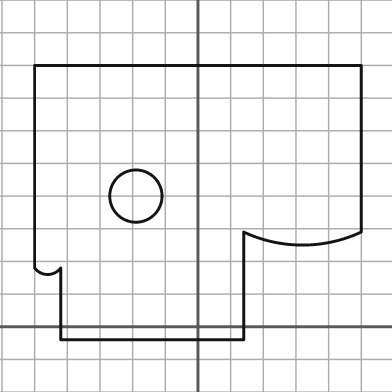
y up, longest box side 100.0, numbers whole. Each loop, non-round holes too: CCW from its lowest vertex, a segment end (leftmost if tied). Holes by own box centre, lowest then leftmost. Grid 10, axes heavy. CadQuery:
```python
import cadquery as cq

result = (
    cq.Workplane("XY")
    .moveTo(-42.0, -4.0)
    .lineTo(14.0, -4.0)
    .lineTo(14.0, 29.0)
    .threePointArc((32.0, 25.0), (50.0, 29.0))
    .lineTo(50.0, 80.0)
    .lineTo(-50.0, 80.0)
    .lineTo(-50.0, 18.0)
    .threePointArc((-46.0, 16.0), (-42.0, 18.0))
    .close()
    .moveTo(-19.0, 40.0)
    .circle(8.0)
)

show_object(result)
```